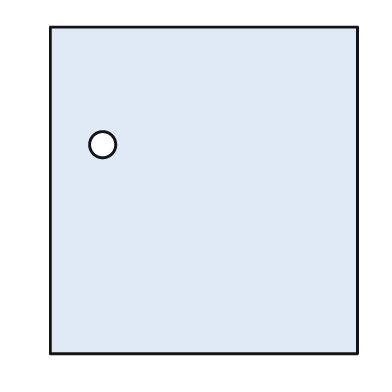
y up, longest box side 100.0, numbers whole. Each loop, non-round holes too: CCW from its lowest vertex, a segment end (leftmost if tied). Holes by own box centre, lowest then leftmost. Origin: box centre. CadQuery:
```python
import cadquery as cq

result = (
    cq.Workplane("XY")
    .moveTo(-47.0, -50.0)
    .lineTo(47.0, -50.0)
    .lineTo(47.0, 50.0)
    .lineTo(-47.0, 50.0)
    .close()
    .moveTo(-31.0, 14.0)
    .circle(4.0)
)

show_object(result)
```